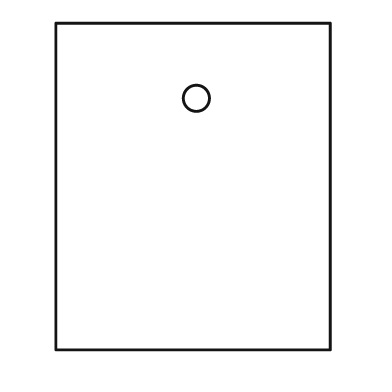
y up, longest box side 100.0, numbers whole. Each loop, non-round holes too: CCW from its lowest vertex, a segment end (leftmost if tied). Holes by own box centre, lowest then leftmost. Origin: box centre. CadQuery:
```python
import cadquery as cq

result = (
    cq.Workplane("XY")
    .moveTo(-42.0, -50.0)
    .lineTo(42.0, -50.0)
    .lineTo(42.0, 50.0)
    .lineTo(-42.0, 50.0)
    .close()
    .moveTo(1.0, 27.0)
    .circle(4.0)
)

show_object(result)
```